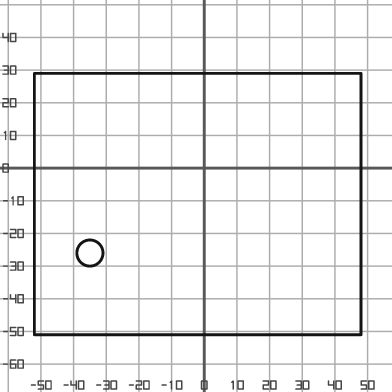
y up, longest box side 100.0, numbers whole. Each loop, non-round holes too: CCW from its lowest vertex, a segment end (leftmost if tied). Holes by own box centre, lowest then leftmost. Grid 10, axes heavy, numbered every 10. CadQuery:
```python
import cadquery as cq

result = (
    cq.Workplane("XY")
    .moveTo(-52.0, -51.0)
    .lineTo(48.0, -51.0)
    .lineTo(48.0, 29.0)
    .lineTo(-52.0, 29.0)
    .close()
    .moveTo(-35.0, -26.0)
    .circle(4.0)
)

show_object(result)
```